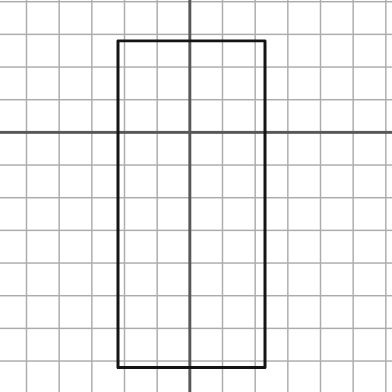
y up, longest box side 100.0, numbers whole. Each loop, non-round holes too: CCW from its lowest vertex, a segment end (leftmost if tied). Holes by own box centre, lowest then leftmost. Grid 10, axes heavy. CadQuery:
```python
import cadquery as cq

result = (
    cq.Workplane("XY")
    .moveTo(-22.0, -72.0)
    .lineTo(23.0, -72.0)
    .lineTo(23.0, 28.0)
    .lineTo(-22.0, 28.0)
    .close()
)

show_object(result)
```